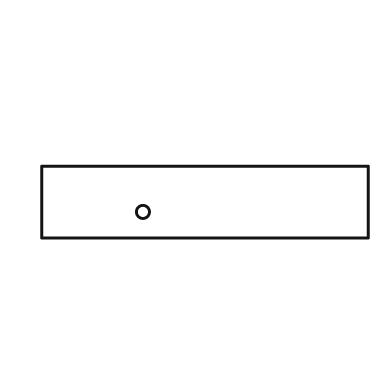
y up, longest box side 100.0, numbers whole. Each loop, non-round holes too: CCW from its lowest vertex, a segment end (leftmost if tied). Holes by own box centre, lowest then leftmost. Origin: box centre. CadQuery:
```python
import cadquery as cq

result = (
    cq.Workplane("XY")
    .moveTo(-50.0, -11.0)
    .lineTo(50.0, -11.0)
    .lineTo(50.0, 11.0)
    .lineTo(-50.0, 11.0)
    .close()
    .moveTo(-19.0, -3.0)
    .circle(2.0)
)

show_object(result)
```